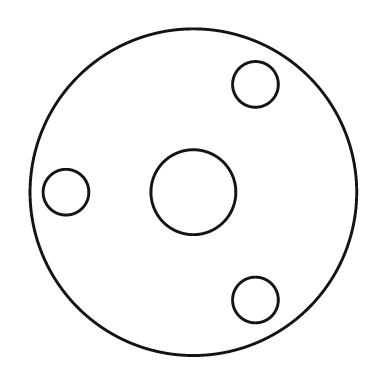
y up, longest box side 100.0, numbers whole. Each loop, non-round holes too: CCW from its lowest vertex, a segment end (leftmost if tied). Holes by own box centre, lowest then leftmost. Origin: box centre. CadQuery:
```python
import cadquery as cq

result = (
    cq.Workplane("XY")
    .moveTo(0.0, 0.0)
    .circle(50.0)
    .moveTo(19.0, -33.0)
    .circle(7.0)
    .moveTo(-39.0, 0.0)
    .circle(7.0)
    .moveTo(0.0, 0.0)
    .circle(13.0)
    .moveTo(19.0, 33.0)
    .circle(7.0)
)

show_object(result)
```